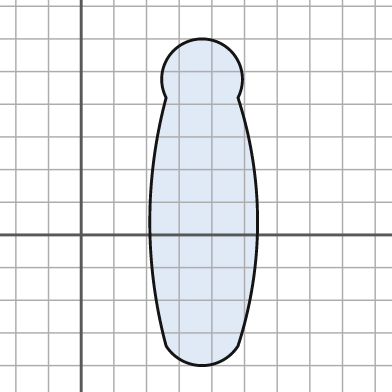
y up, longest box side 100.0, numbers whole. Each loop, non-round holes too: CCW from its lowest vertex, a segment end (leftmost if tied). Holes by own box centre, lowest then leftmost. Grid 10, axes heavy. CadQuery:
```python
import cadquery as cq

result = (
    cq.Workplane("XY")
    .moveTo(26.0, -34.0)
    .threePointArc((37.0, -40.0), (48.0, -34.0))
    .threePointArc((54.0, 4.0), (48.0, 42.0))
    .threePointArc((37.0, 60.0), (26.0, 42.0))
    .threePointArc((21.0, 4.0), (26.0, -34.0))
    .close()
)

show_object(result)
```